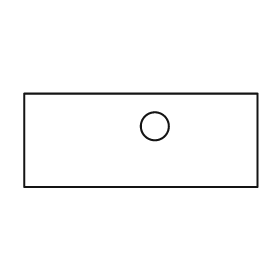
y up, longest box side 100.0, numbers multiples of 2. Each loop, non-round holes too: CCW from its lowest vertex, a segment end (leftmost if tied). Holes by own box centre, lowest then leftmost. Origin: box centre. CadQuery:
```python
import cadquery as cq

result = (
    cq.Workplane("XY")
    .moveTo(-50.0, -20.0)
    .lineTo(50.0, -20.0)
    .lineTo(50.0, 20.0)
    .lineTo(-50.0, 20.0)
    .close()
    .moveTo(6.0, 6.0)
    .circle(6.0)
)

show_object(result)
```